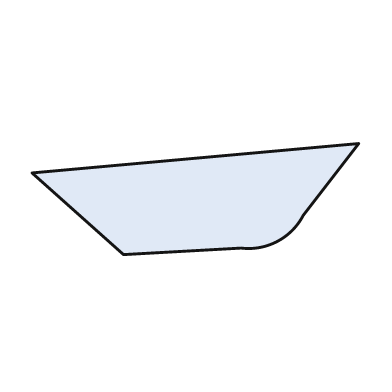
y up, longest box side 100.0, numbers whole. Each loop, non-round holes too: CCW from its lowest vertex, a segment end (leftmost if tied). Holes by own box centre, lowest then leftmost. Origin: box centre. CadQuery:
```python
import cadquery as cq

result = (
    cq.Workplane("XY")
    .moveTo(-22.0, -17.0)
    .lineTo(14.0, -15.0)
    .threePointArc((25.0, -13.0), (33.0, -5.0))
    .lineTo(50.0, 17.0)
    .lineTo(-50.0, 8.0)
    .close()
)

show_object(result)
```